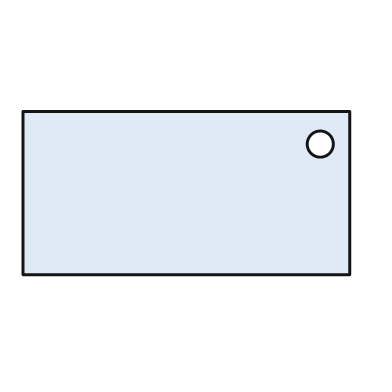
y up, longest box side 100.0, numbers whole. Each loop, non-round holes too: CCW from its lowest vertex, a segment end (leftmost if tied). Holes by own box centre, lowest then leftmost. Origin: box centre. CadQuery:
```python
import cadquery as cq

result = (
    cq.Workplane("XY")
    .moveTo(-50.0, -25.0)
    .lineTo(50.0, -25.0)
    .lineTo(50.0, 25.0)
    .lineTo(-50.0, 25.0)
    .close()
    .moveTo(41.0, 15.0)
    .circle(4.0)
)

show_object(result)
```